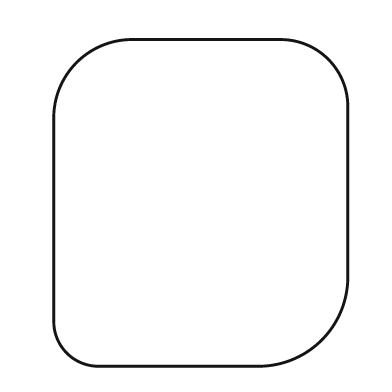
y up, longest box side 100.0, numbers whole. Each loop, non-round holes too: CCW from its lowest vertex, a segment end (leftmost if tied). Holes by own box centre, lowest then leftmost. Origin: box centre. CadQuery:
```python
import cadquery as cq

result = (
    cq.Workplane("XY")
    .moveTo(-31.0, -50.0)
    .lineTo(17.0, -50.0)
    .threePointArc((37.0, -42.0), (45.0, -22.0))
    .lineTo(45.0, 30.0)
    .threePointArc((39.0, 44.0), (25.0, 50.0))
    .lineTo(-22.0, 50.0)
    .threePointArc((-38.0, 43.0), (-45.0, 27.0))
    .lineTo(-45.0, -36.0)
    .threePointArc((-41.0, -46.0), (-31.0, -50.0))
    .close()
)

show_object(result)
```